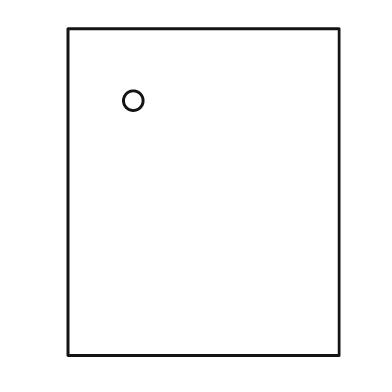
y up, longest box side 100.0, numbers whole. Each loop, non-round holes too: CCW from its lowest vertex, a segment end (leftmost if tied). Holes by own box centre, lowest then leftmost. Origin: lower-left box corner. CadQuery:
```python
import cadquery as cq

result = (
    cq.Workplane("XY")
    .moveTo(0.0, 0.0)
    .lineTo(83.0, 0.0)
    .lineTo(83.0, 100.0)
    .lineTo(0.0, 100.0)
    .close()
    .moveTo(20.0, 78.0)
    .circle(3.0)
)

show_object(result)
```